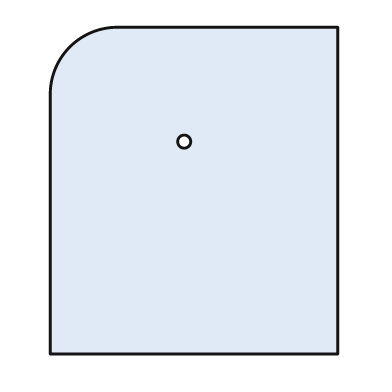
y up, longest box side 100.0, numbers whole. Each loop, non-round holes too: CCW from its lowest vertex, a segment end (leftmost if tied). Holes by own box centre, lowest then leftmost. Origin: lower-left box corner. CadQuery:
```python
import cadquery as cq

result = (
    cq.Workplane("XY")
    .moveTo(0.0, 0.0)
    .lineTo(88.0, 0.0)
    .lineTo(88.0, 100.0)
    .lineTo(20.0, 100.0)
    .threePointArc((6.0, 94.0), (0.0, 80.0))
    .close()
    .moveTo(41.0, 65.0)
    .circle(2.0)
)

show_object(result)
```